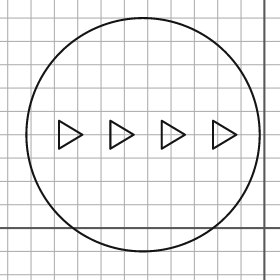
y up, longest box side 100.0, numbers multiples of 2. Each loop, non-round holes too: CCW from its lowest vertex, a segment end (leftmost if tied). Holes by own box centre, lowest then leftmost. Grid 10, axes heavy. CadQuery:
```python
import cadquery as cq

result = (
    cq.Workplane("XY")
    .moveTo(-52.0, 40.0)
    .circle(50.0)
    .moveTo(-88.0, 34.0)
    .lineTo(-78.0, 40.0)
    .lineTo(-88.0, 46.0)
    .close()
    .moveTo(-66.0, 34.0)
    .lineTo(-56.0, 40.0)
    .lineTo(-66.0, 46.0)
    .close()
    .moveTo(-44.0, 34.0)
    .lineTo(-34.0, 40.0)
    .lineTo(-44.0, 46.0)
    .close()
    .moveTo(-22.0, 34.0)
    .lineTo(-12.0, 40.0)
    .lineTo(-22.0, 46.0)
    .close()
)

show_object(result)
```